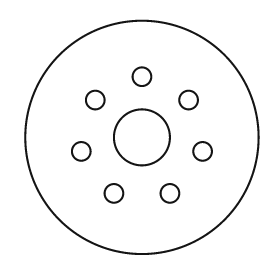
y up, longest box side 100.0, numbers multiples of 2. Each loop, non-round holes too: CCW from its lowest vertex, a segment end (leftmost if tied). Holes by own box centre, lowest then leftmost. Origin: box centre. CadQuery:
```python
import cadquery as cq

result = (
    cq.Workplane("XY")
    .moveTo(0.0, 0.0)
    .circle(50.0)
    .moveTo(-12.0, -24.0)
    .circle(4.0)
    .moveTo(12.0, -24.0)
    .circle(4.0)
    .moveTo(-26.0, -6.0)
    .circle(4.0)
    .moveTo(26.0, -6.0)
    .circle(4.0)
    .moveTo(0.0, 0.0)
    .circle(12.0)
    .moveTo(-20.0, 16.0)
    .circle(4.0)
    .moveTo(20.0, 16.0)
    .circle(4.0)
    .moveTo(0.0, 26.0)
    .circle(4.0)
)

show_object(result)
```